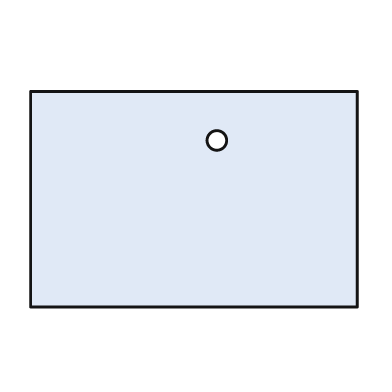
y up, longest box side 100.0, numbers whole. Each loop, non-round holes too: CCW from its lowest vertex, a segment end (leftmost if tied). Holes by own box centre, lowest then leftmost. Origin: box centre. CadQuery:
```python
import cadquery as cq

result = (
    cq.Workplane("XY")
    .moveTo(-50.0, -33.0)
    .lineTo(50.0, -33.0)
    .lineTo(50.0, 33.0)
    .lineTo(-50.0, 33.0)
    .close()
    .moveTo(7.0, 18.0)
    .circle(3.0)
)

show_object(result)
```